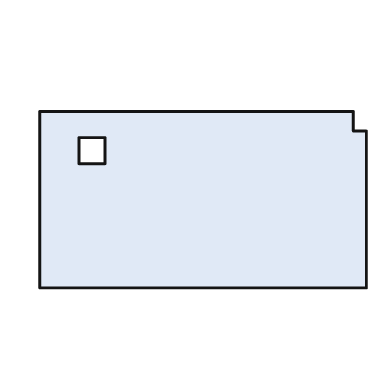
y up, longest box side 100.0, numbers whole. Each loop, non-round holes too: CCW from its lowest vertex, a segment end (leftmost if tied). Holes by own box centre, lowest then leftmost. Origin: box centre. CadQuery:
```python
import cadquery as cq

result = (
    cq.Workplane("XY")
    .moveTo(-50.0, -27.0)
    .lineTo(50.0, -27.0)
    .lineTo(50.0, 21.0)
    .lineTo(46.0, 21.0)
    .lineTo(46.0, 27.0)
    .lineTo(-50.0, 27.0)
    .close()
    .moveTo(-38.0, 11.0)
    .lineTo(-30.0, 11.0)
    .lineTo(-30.0, 19.0)
    .lineTo(-38.0, 19.0)
    .close()
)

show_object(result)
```